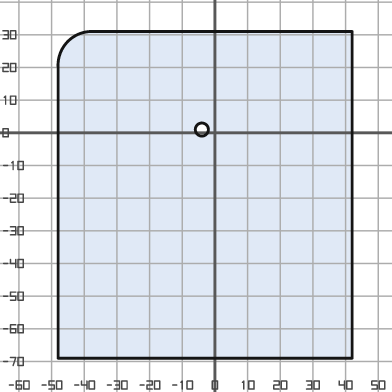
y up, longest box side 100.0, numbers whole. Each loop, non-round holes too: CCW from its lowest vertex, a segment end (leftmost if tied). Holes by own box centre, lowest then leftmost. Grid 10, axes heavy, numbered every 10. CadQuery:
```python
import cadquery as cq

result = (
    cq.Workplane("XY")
    .moveTo(-48.0, -69.0)
    .lineTo(42.0, -69.0)
    .lineTo(42.0, 31.0)
    .lineTo(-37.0, 31.0)
    .threePointArc((-45.0, 28.0), (-48.0, 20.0))
    .close()
    .moveTo(-4.0, 1.0)
    .circle(2.0)
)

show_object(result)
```